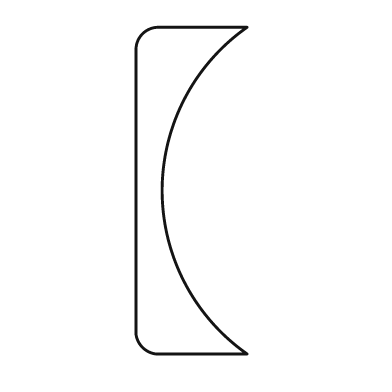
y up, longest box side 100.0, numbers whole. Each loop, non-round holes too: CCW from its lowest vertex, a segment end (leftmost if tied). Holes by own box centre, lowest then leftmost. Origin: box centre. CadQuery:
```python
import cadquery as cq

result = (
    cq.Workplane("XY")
    .moveTo(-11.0, -50.0)
    .lineTo(17.0, -50.0)
    .threePointArc((-9.0, 0.0), (17.0, 50.0))
    .lineTo(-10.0, 50.0)
    .threePointArc((-15.0, 48.0), (-17.0, 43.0))
    .lineTo(-17.0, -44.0)
    .threePointArc((-15.0, -48.0), (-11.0, -50.0))
    .close()
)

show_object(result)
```